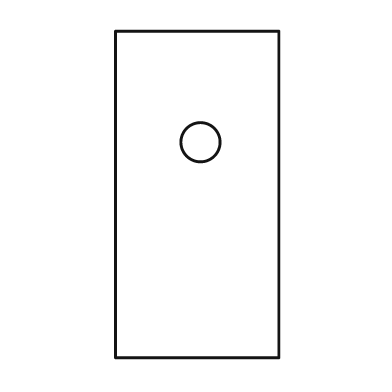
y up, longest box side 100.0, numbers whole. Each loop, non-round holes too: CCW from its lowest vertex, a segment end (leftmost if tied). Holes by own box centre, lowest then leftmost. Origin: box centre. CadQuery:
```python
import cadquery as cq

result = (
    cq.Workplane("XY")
    .moveTo(-25.0, -50.0)
    .lineTo(25.0, -50.0)
    .lineTo(25.0, 50.0)
    .lineTo(-25.0, 50.0)
    .close()
    .moveTo(1.0, 16.0)
    .circle(6.0)
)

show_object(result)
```